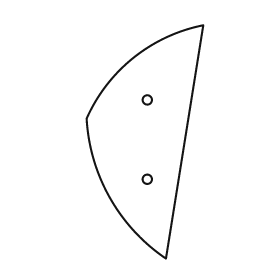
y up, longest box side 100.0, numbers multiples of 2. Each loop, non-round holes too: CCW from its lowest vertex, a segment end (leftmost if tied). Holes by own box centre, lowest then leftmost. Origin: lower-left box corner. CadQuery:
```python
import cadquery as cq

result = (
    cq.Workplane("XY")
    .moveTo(34.0, 0.0)
    .lineTo(50.0, 100.0)
    .threePointArc((20.0, 86.0), (0.0, 60.0))
    .threePointArc((10.0, 26.0), (34.0, 0.0))
    .close()
    .moveTo(26.0, 34.0)
    .circle(2.0)
    .moveTo(26.0, 68.0)
    .circle(2.0)
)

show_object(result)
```